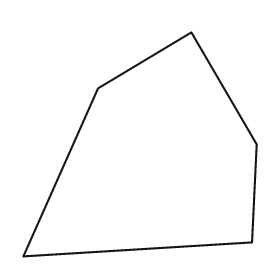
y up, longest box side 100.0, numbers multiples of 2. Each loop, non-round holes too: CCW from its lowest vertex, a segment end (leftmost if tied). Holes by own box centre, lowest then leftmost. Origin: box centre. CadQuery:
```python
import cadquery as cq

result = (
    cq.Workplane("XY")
    .moveTo(-50.0, -48.0)
    .lineTo(48.0, -42.0)
    .lineTo(50.0, 0.0)
    .lineTo(22.0, 48.0)
    .lineTo(-18.0, 24.0)
    .close()
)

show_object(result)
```